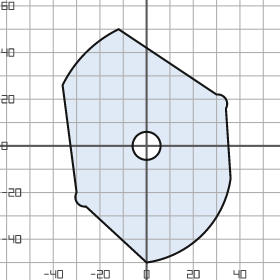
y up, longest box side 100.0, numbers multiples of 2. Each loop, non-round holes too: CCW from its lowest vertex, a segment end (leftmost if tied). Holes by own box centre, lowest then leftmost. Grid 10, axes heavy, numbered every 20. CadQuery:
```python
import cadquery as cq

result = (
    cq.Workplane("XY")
    .moveTo(0.0, -50.0)
    .threePointArc((24.0, -38.0), (36.0, -14.0))
    .lineTo(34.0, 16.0)
    .threePointArc((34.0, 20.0), (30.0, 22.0))
    .lineTo(-12.0, 50.0)
    .threePointArc((-26.0, 40.0), (-36.0, 26.0))
    .lineTo(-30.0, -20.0)
    .threePointArc((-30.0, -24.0), (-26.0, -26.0))
    .close()
    .moveTo(0.0, 0.0)
    .circle(6.0)
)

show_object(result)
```